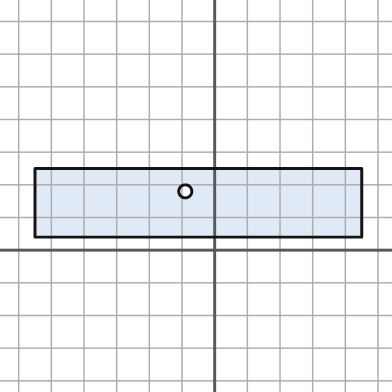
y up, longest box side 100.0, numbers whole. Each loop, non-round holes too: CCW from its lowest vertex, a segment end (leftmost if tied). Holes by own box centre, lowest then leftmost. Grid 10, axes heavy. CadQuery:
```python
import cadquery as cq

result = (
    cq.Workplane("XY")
    .moveTo(-55.0, 4.0)
    .lineTo(45.0, 4.0)
    .lineTo(45.0, 25.0)
    .lineTo(-55.0, 25.0)
    .close()
    .moveTo(-9.0, 18.0)
    .circle(2.0)
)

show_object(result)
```